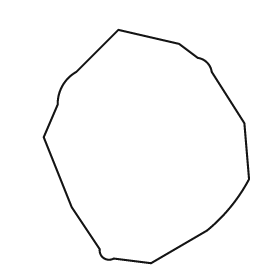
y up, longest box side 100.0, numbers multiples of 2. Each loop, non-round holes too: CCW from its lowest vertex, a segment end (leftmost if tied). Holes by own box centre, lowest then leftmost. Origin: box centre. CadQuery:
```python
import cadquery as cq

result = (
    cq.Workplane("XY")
    .moveTo(2.0, -50.0)
    .lineTo(26.0, -36.0)
    .threePointArc((36.0, -26.0), (44.0, -14.0))
    .lineTo(42.0, 10.0)
    .lineTo(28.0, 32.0)
    .threePointArc((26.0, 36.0), (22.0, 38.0))
    .lineTo(14.0, 44.0)
    .lineTo(-12.0, 50.0)
    .lineTo(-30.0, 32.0)
    .threePointArc((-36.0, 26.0), (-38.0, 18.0))
    .lineTo(-44.0, 4.0)
    .lineTo(-32.0, -26.0)
    .lineTo(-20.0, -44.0)
    .threePointArc((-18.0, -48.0), (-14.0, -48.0))
    .close()
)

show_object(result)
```